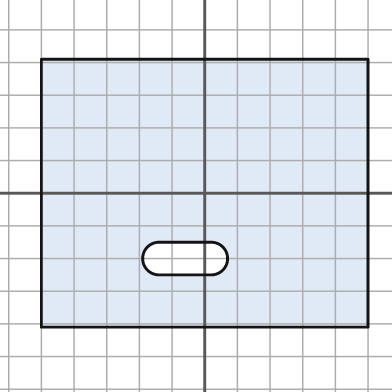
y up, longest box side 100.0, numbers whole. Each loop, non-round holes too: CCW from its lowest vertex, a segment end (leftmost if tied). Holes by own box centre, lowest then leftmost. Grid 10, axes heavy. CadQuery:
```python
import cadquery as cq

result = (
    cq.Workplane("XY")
    .moveTo(-50.0, -41.0)
    .lineTo(50.0, -41.0)
    .lineTo(50.0, 41.0)
    .lineTo(-50.0, 41.0)
    .close()
    .moveTo(-14.0, -25.0)
    .lineTo(2.0, -25.0)
    .threePointArc((7.0, -20.0), (2.0, -15.0))
    .lineTo(-14.0, -15.0)
    .threePointArc((-19.0, -20.0), (-14.0, -25.0))
    .close()
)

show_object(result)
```